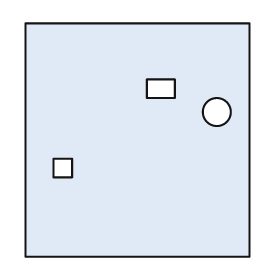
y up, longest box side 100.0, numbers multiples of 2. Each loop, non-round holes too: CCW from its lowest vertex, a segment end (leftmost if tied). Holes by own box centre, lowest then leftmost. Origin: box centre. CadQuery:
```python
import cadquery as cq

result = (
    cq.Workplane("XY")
    .moveTo(-48.0, -50.0)
    .lineTo(48.0, -50.0)
    .lineTo(48.0, 50.0)
    .lineTo(-48.0, 50.0)
    .close()
    .moveTo(-36.0, -16.0)
    .lineTo(-28.0, -16.0)
    .lineTo(-28.0, -8.0)
    .lineTo(-36.0, -8.0)
    .close()
    .moveTo(34.0, 12.0)
    .circle(6.0)
    .moveTo(4.0, 18.0)
    .lineTo(16.0, 18.0)
    .lineTo(16.0, 26.0)
    .lineTo(4.0, 26.0)
    .close()
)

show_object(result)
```